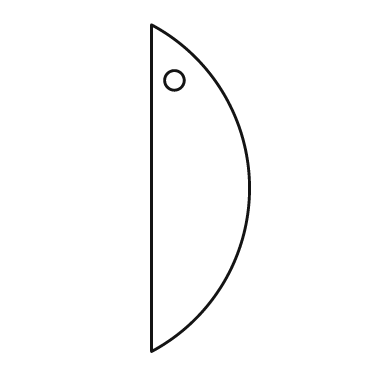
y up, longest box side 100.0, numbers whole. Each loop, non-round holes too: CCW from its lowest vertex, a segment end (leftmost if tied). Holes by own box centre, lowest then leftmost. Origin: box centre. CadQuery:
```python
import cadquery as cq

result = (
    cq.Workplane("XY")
    .moveTo(-15.0, -50.0)
    .threePointArc((15.0, 0.0), (-15.0, 50.0))
    .close()
    .moveTo(-8.0, 33.0)
    .circle(3.0)
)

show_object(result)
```